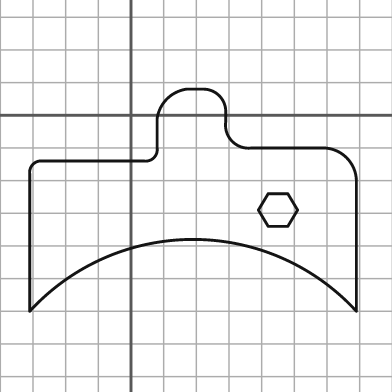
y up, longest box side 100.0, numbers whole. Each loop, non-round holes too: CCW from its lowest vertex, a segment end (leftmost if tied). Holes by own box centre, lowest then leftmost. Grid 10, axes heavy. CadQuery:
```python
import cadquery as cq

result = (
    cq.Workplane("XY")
    .moveTo(-31.0, -60.0)
    .threePointArc((19.0, -38.0), (69.0, -60.0))
    .lineTo(69.0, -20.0)
    .threePointArc((66.0, -13.0), (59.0, -10.0))
    .lineTo(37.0, -10.0)
    .threePointArc((31.0, -8.0), (29.0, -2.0))
    .lineTo(29.0, 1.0)
    .threePointArc((27.0, 6.0), (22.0, 8.0))
    .lineTo(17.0, 8.0)
    .threePointArc((11.0, 5.0), (8.0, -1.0))
    .lineTo(8.0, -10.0)
    .threePointArc((7.0, -13.0), (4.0, -14.0))
    .lineTo(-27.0, -14.0)
    .threePointArc((-30.0, -15.0), (-31.0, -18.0))
    .close()
    .moveTo(42.0, -34.0)
    .lineTo(48.0, -34.0)
    .lineTo(51.0, -29.0)
    .lineTo(48.0, -24.0)
    .lineTo(42.0, -24.0)
    .lineTo(39.0, -29.0)
    .close()
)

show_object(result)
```